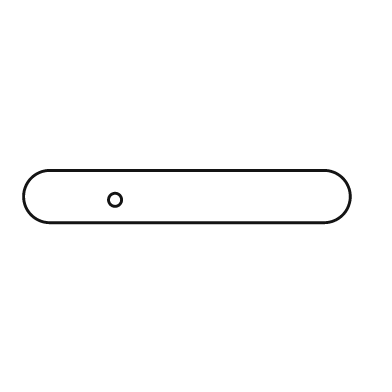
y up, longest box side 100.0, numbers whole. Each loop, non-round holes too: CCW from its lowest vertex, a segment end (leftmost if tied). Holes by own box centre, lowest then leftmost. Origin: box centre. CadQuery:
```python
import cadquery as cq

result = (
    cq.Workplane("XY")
    .moveTo(-42.0, -8.0)
    .lineTo(42.0, -8.0)
    .threePointArc((50.0, 0.0), (42.0, 8.0))
    .lineTo(-42.0, 8.0)
    .threePointArc((-50.0, 0.0), (-42.0, -8.0))
    .close()
    .moveTo(-22.0, -1.0)
    .circle(2.0)
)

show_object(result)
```